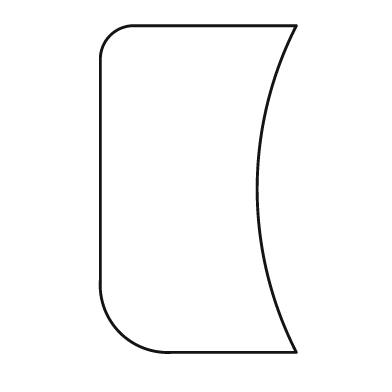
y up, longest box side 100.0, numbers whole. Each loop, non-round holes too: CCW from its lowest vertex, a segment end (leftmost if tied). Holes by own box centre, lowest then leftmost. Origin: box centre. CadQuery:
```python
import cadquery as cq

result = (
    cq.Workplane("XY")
    .moveTo(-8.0, -50.0)
    .lineTo(30.0, -50.0)
    .threePointArc((18.0, 0.0), (30.0, 50.0))
    .lineTo(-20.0, 50.0)
    .threePointArc((-27.0, 47.0), (-30.0, 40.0))
    .lineTo(-30.0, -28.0)
    .threePointArc((-24.0, -44.0), (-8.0, -50.0))
    .close()
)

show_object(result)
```